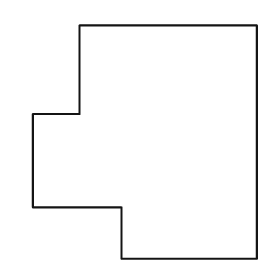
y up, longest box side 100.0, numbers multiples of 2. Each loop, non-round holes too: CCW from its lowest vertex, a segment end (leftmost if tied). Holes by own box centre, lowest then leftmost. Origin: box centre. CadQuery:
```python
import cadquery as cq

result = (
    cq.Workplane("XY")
    .moveTo(-10.0, -50.0)
    .lineTo(48.0, -50.0)
    .lineTo(48.0, 50.0)
    .lineTo(-28.0, 50.0)
    .lineTo(-28.0, 12.0)
    .lineTo(-48.0, 12.0)
    .lineTo(-48.0, -28.0)
    .lineTo(-10.0, -28.0)
    .close()
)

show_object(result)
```